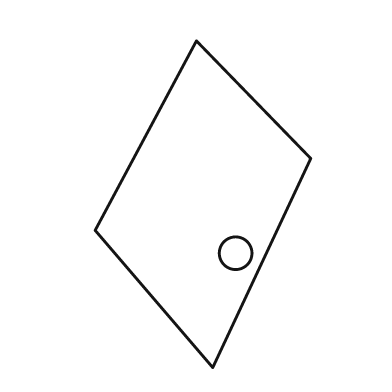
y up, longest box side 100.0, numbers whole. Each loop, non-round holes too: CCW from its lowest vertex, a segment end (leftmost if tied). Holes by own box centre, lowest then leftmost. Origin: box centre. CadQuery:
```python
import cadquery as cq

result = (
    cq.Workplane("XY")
    .moveTo(3.0, -50.0)
    .lineTo(33.0, 14.0)
    .lineTo(-2.0, 50.0)
    .lineTo(-33.0, -8.0)
    .close()
    .moveTo(10.0, -15.0)
    .circle(5.0)
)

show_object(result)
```